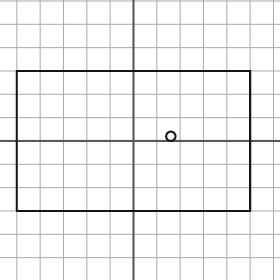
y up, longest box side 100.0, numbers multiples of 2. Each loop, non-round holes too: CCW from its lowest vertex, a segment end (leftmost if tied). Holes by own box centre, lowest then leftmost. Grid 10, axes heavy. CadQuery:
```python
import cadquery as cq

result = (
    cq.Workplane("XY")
    .moveTo(-50.0, -30.0)
    .lineTo(50.0, -30.0)
    .lineTo(50.0, 30.0)
    .lineTo(-50.0, 30.0)
    .close()
    .moveTo(16.0, 2.0)
    .circle(2.0)
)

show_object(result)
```